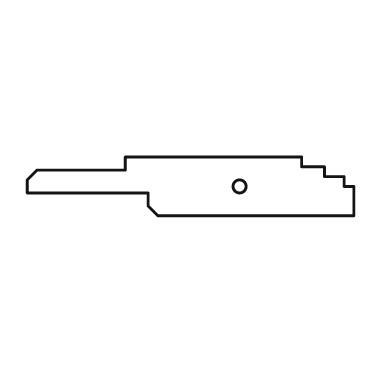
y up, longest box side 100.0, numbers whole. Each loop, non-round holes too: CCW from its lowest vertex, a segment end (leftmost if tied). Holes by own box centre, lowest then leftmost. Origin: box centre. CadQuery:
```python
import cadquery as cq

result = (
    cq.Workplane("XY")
    .moveTo(-10.0, -9.0)
    .lineTo(50.0, -9.0)
    .lineTo(50.0, 0.0)
    .lineTo(47.0, 0.0)
    .lineTo(47.0, 3.0)
    .lineTo(41.0, 3.0)
    .lineTo(41.0, 6.0)
    .lineTo(34.0, 6.0)
    .lineTo(34.0, 9.0)
    .lineTo(-20.0, 9.0)
    .lineTo(-20.0, 5.0)
    .lineTo(-47.0, 5.0)
    .lineTo(-50.0, 2.0)
    .lineTo(-50.0, -2.0)
    .lineTo(-13.0, -2.0)
    .lineTo(-13.0, -6.0)
    .close()
    .moveTo(15.0, 0.0)
    .circle(2.0)
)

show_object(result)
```